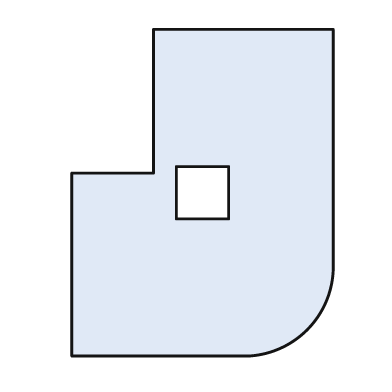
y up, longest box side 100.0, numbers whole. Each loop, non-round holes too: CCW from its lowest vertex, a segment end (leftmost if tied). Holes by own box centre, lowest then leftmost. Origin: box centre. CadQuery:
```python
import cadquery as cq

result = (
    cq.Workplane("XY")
    .moveTo(-40.0, -50.0)
    .lineTo(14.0, -50.0)
    .threePointArc((32.0, -42.0), (40.0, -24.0))
    .lineTo(40.0, 50.0)
    .lineTo(-15.0, 50.0)
    .lineTo(-15.0, 6.0)
    .lineTo(-40.0, 6.0)
    .close()
    .moveTo(-8.0, -8.0)
    .lineTo(8.0, -8.0)
    .lineTo(8.0, 8.0)
    .lineTo(-8.0, 8.0)
    .close()
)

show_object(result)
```